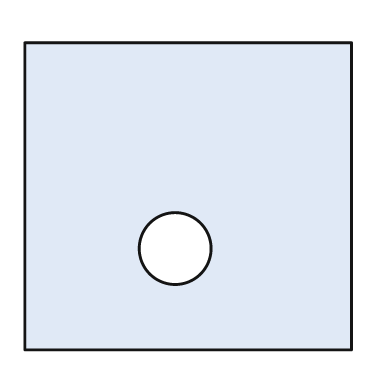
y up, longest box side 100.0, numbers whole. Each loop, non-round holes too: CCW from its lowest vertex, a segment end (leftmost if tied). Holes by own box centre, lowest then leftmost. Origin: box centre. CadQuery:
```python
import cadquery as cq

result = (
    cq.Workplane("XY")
    .moveTo(-50.0, -47.0)
    .lineTo(50.0, -47.0)
    .lineTo(50.0, 47.0)
    .lineTo(-50.0, 47.0)
    .close()
    .moveTo(-4.0, -16.0)
    .circle(11.0)
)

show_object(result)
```